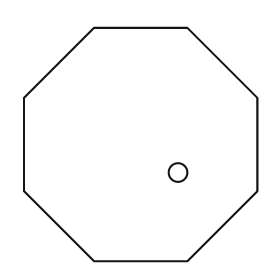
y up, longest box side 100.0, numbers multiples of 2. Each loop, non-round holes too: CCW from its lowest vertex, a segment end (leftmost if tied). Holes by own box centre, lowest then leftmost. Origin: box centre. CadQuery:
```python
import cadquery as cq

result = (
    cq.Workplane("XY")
    .moveTo(-20.0, -50.0)
    .lineTo(20.0, -50.0)
    .lineTo(50.0, -20.0)
    .lineTo(50.0, 20.0)
    .lineTo(20.0, 50.0)
    .lineTo(-20.0, 50.0)
    .lineTo(-50.0, 20.0)
    .lineTo(-50.0, -20.0)
    .close()
    .moveTo(16.0, -12.0)
    .circle(4.0)
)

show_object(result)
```